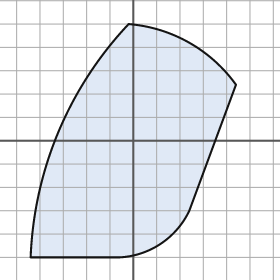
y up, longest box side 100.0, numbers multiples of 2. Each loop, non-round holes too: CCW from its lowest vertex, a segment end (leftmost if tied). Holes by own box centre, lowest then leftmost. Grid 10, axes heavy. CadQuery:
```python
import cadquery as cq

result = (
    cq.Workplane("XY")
    .moveTo(-44.0, -50.0)
    .lineTo(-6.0, -50.0)
    .threePointArc((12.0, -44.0), (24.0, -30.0))
    .lineTo(44.0, 24.0)
    .threePointArc((24.0, 42.0), (-2.0, 50.0))
    .threePointArc((-32.0, 4.0), (-44.0, -50.0))
    .close()
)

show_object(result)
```